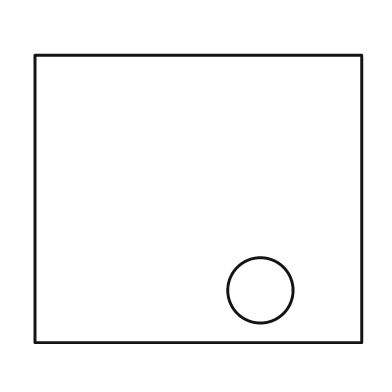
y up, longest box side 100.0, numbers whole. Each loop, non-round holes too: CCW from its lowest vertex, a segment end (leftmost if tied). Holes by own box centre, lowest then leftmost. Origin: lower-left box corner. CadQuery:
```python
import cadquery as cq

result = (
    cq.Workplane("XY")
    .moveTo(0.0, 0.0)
    .lineTo(100.0, 0.0)
    .lineTo(100.0, 88.0)
    .lineTo(0.0, 88.0)
    .close()
    .moveTo(69.0, 16.0)
    .circle(10.0)
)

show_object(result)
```